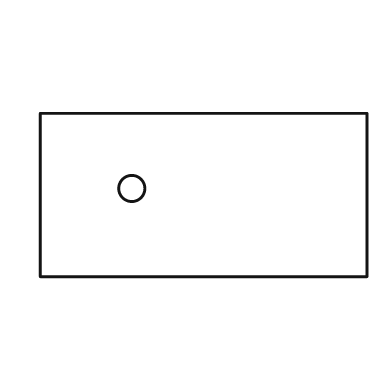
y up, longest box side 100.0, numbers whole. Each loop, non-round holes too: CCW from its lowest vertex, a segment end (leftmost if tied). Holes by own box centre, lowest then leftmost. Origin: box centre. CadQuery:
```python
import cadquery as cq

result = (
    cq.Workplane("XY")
    .moveTo(-50.0, -25.0)
    .lineTo(50.0, -25.0)
    .lineTo(50.0, 25.0)
    .lineTo(-50.0, 25.0)
    .close()
    .moveTo(-22.0, 2.0)
    .circle(4.0)
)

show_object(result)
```